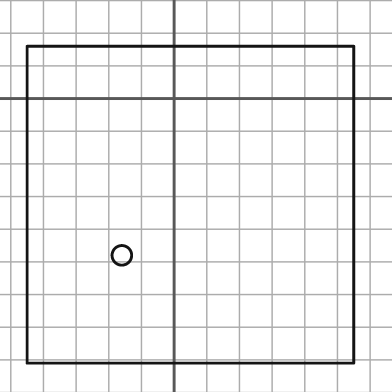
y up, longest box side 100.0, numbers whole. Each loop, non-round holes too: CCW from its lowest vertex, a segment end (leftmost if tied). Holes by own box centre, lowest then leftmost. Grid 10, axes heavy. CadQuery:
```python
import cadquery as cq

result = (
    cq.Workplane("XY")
    .moveTo(-45.0, -81.0)
    .lineTo(55.0, -81.0)
    .lineTo(55.0, 16.0)
    .lineTo(-45.0, 16.0)
    .close()
    .moveTo(-16.0, -48.0)
    .circle(3.0)
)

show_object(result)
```